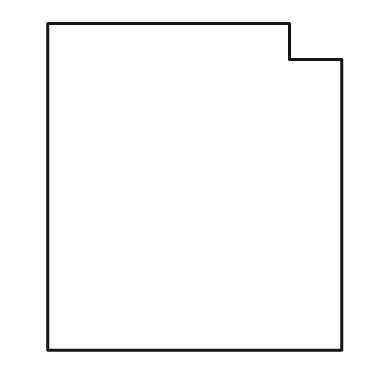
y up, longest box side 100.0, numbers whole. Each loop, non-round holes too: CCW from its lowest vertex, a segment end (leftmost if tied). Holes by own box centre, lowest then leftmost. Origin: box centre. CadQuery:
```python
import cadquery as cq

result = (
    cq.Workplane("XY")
    .moveTo(-45.0, -50.0)
    .lineTo(45.0, -50.0)
    .lineTo(45.0, 39.0)
    .lineTo(29.0, 39.0)
    .lineTo(29.0, 50.0)
    .lineTo(-45.0, 50.0)
    .close()
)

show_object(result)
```